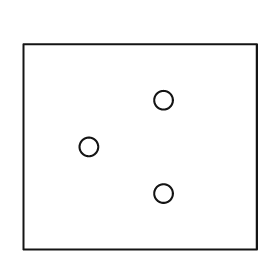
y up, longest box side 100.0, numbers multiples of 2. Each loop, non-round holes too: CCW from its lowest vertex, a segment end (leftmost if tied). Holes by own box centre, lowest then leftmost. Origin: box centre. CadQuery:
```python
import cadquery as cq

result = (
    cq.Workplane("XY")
    .moveTo(-50.0, -44.0)
    .lineTo(50.0, -44.0)
    .lineTo(50.0, 44.0)
    .lineTo(-50.0, 44.0)
    .close()
    .moveTo(10.0, -20.0)
    .circle(4.0)
    .moveTo(-22.0, 0.0)
    .circle(4.0)
    .moveTo(10.0, 20.0)
    .circle(4.0)
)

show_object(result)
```